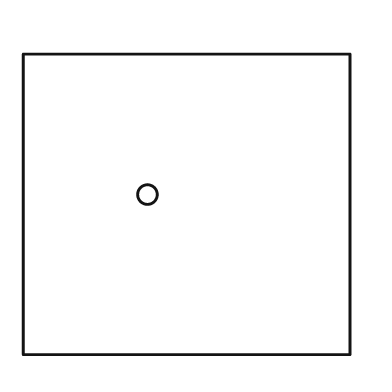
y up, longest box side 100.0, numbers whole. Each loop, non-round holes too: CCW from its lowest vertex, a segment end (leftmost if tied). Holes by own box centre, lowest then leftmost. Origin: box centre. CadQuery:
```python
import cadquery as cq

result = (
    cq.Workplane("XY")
    .moveTo(-50.0, -46.0)
    .lineTo(50.0, -46.0)
    .lineTo(50.0, 46.0)
    .lineTo(-50.0, 46.0)
    .close()
    .moveTo(-12.0, 3.0)
    .circle(3.0)
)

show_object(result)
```